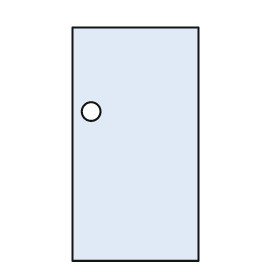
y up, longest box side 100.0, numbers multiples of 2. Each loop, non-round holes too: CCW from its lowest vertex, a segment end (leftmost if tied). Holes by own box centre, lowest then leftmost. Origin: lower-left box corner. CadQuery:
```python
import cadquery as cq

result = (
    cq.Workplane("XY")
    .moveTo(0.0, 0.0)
    .lineTo(54.0, 0.0)
    .lineTo(54.0, 100.0)
    .lineTo(0.0, 100.0)
    .close()
    .moveTo(8.0, 64.0)
    .circle(4.0)
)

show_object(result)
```